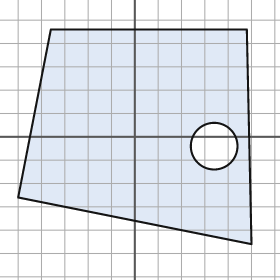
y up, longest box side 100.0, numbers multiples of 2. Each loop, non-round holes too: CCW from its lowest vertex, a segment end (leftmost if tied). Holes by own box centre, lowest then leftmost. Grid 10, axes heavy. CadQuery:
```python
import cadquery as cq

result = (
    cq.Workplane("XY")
    .moveTo(50.0, -46.0)
    .lineTo(48.0, 46.0)
    .lineTo(-36.0, 46.0)
    .lineTo(-50.0, -26.0)
    .close()
    .moveTo(34.0, -4.0)
    .circle(10.0)
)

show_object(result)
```